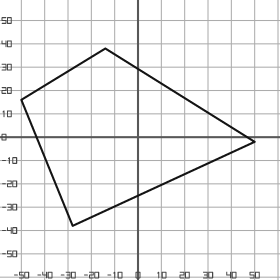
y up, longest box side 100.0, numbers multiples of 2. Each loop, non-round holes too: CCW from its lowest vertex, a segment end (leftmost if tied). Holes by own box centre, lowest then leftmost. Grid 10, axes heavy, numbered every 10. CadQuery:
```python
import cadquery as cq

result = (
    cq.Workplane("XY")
    .moveTo(-28.0, -38.0)
    .lineTo(50.0, -2.0)
    .lineTo(-14.0, 38.0)
    .lineTo(-50.0, 16.0)
    .close()
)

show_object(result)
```